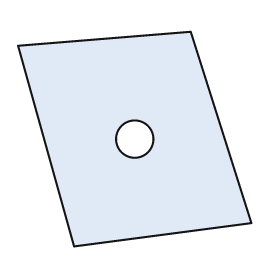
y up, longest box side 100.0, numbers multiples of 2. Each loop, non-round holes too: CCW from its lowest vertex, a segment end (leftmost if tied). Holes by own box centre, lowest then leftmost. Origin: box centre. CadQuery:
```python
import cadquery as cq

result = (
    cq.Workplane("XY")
    .moveTo(-26.0, -46.0)
    .lineTo(50.0, -36.0)
    .lineTo(24.0, 46.0)
    .lineTo(-50.0, 40.0)
    .close()
    .moveTo(0.0, 0.0)
    .circle(8.0)
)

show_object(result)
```